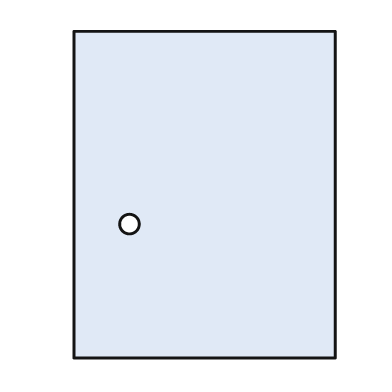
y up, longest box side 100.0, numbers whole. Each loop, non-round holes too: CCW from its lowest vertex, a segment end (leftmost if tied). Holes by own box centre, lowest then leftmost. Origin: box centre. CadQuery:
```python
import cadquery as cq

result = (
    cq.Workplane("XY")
    .moveTo(-40.0, -50.0)
    .lineTo(40.0, -50.0)
    .lineTo(40.0, 50.0)
    .lineTo(-40.0, 50.0)
    .close()
    .moveTo(-23.0, -9.0)
    .circle(3.0)
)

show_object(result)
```